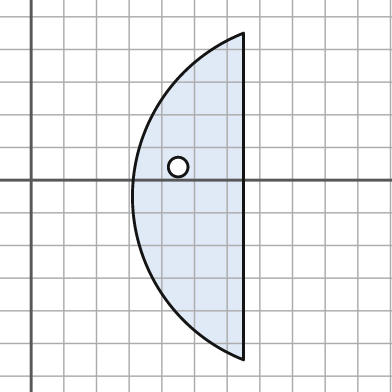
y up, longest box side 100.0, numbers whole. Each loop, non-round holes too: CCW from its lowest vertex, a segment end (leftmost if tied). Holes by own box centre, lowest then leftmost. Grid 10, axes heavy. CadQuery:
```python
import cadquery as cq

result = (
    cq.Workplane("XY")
    .moveTo(65.0, -55.0)
    .lineTo(65.0, 45.0)
    .threePointArc((31.0, -5.0), (65.0, -55.0))
    .close()
    .moveTo(45.0, 4.0)
    .circle(3.0)
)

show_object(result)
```